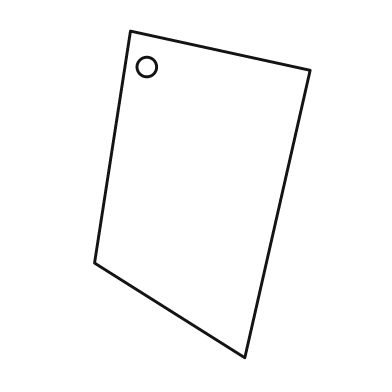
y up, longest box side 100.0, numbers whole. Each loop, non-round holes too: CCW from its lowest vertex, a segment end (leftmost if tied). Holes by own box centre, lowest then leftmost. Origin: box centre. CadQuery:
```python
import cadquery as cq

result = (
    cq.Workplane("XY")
    .moveTo(13.0, -50.0)
    .lineTo(33.0, 38.0)
    .lineTo(-22.0, 50.0)
    .lineTo(-33.0, -21.0)
    .close()
    .moveTo(-17.0, 39.0)
    .circle(3.0)
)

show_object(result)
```